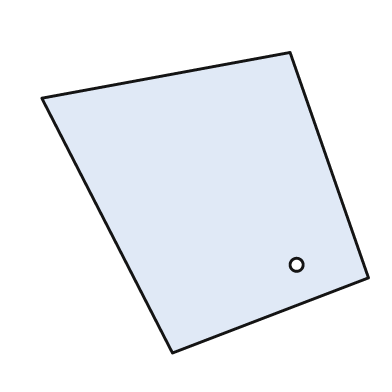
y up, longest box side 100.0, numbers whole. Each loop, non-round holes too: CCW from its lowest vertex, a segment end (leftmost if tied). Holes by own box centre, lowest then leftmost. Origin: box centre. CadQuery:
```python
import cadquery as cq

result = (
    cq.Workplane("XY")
    .moveTo(-10.0, -46.0)
    .lineTo(50.0, -23.0)
    .lineTo(26.0, 46.0)
    .lineTo(-50.0, 32.0)
    .close()
    .moveTo(28.0, -19.0)
    .circle(2.0)
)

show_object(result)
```